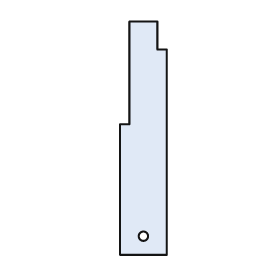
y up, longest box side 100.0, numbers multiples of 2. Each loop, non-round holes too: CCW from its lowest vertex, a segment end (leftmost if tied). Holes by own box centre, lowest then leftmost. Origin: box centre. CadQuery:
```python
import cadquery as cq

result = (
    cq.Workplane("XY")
    .moveTo(-10.0, -50.0)
    .lineTo(10.0, -50.0)
    .lineTo(10.0, 38.0)
    .lineTo(6.0, 38.0)
    .lineTo(6.0, 50.0)
    .lineTo(-6.0, 50.0)
    .lineTo(-6.0, 6.0)
    .lineTo(-10.0, 6.0)
    .close()
    .moveTo(0.0, -42.0)
    .circle(2.0)
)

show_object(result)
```